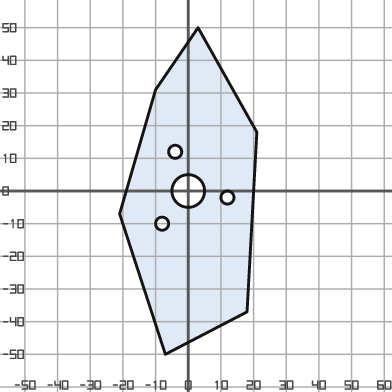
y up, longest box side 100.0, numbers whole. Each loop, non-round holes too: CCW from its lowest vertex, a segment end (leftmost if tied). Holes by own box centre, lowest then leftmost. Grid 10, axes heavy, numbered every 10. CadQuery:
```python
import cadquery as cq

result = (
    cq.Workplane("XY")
    .moveTo(-7.0, -50.0)
    .lineTo(18.0, -37.0)
    .lineTo(21.0, 18.0)
    .lineTo(3.0, 50.0)
    .lineTo(-10.0, 31.0)
    .lineTo(-21.0, -7.0)
    .close()
    .moveTo(-8.0, -10.0)
    .circle(2.0)
    .moveTo(12.0, -2.0)
    .circle(2.0)
    .moveTo(0.0, 0.0)
    .circle(5.0)
    .moveTo(-4.0, 12.0)
    .circle(2.0)
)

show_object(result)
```